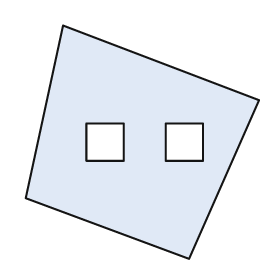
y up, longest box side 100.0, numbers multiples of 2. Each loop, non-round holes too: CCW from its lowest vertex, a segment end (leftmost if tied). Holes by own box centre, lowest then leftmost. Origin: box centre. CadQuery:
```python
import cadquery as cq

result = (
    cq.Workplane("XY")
    .moveTo(20.0, -50.0)
    .lineTo(50.0, 18.0)
    .lineTo(-34.0, 50.0)
    .lineTo(-50.0, -24.0)
    .close()
    .moveTo(-24.0, -8.0)
    .lineTo(-8.0, -8.0)
    .lineTo(-8.0, 8.0)
    .lineTo(-24.0, 8.0)
    .close()
    .moveTo(10.0, -8.0)
    .lineTo(26.0, -8.0)
    .lineTo(26.0, 8.0)
    .lineTo(10.0, 8.0)
    .close()
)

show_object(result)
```